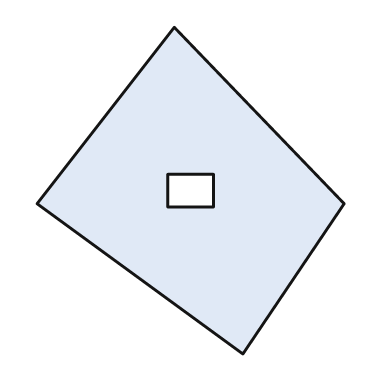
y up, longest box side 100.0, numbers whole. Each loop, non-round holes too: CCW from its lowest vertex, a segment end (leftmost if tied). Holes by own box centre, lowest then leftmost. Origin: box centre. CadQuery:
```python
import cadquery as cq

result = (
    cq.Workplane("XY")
    .moveTo(16.0, -50.0)
    .lineTo(47.0, -4.0)
    .lineTo(-5.0, 50.0)
    .lineTo(-47.0, -4.0)
    .close()
    .moveTo(-7.0, -5.0)
    .lineTo(7.0, -5.0)
    .lineTo(7.0, 5.0)
    .lineTo(-7.0, 5.0)
    .close()
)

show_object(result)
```